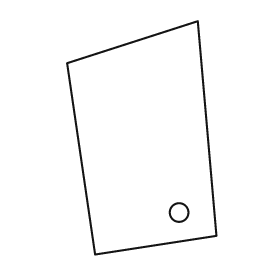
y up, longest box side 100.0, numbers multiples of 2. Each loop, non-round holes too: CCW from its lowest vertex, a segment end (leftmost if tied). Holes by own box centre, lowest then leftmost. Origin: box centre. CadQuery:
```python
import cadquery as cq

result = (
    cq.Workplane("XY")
    .moveTo(-20.0, -50.0)
    .lineTo(32.0, -42.0)
    .lineTo(24.0, 50.0)
    .lineTo(-32.0, 32.0)
    .close()
    .moveTo(16.0, -32.0)
    .circle(4.0)
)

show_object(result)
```